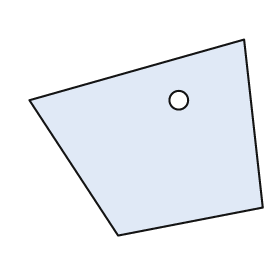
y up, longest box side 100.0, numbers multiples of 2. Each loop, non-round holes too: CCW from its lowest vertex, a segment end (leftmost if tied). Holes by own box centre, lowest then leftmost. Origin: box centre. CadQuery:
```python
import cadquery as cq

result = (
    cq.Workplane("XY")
    .moveTo(-12.0, -42.0)
    .lineTo(50.0, -30.0)
    .lineTo(42.0, 42.0)
    .lineTo(-50.0, 16.0)
    .close()
    .moveTo(14.0, 16.0)
    .circle(4.0)
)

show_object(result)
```